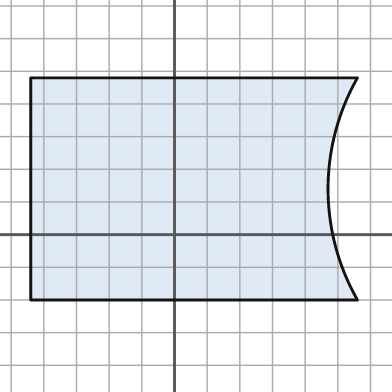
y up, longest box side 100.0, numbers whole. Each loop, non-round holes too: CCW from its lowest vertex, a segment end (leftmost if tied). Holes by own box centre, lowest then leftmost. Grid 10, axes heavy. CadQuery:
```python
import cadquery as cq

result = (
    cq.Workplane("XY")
    .moveTo(-44.0, -20.0)
    .lineTo(56.0, -20.0)
    .threePointArc((47.0, 14.0), (56.0, 48.0))
    .lineTo(-44.0, 48.0)
    .close()
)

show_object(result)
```